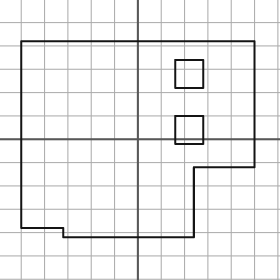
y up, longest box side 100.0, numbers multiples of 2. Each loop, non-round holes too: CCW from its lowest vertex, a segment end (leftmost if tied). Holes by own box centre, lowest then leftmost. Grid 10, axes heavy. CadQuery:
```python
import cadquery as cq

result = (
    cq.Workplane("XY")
    .moveTo(-32.0, -42.0)
    .lineTo(24.0, -42.0)
    .lineTo(24.0, -12.0)
    .lineTo(50.0, -12.0)
    .lineTo(50.0, 42.0)
    .lineTo(-50.0, 42.0)
    .lineTo(-50.0, -38.0)
    .lineTo(-32.0, -38.0)
    .close()
    .moveTo(16.0, -2.0)
    .lineTo(28.0, -2.0)
    .lineTo(28.0, 10.0)
    .lineTo(16.0, 10.0)
    .close()
    .moveTo(16.0, 22.0)
    .lineTo(28.0, 22.0)
    .lineTo(28.0, 34.0)
    .lineTo(16.0, 34.0)
    .close()
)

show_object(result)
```